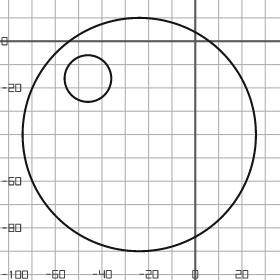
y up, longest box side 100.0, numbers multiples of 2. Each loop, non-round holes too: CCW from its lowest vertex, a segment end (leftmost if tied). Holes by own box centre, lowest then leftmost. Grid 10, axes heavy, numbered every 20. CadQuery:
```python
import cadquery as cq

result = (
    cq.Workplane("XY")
    .moveTo(-24.0, -40.0)
    .circle(50.0)
    .moveTo(-46.0, -16.0)
    .circle(10.0)
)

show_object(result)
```